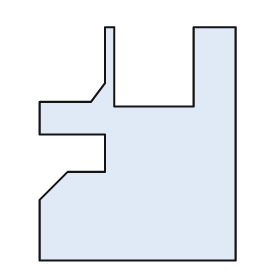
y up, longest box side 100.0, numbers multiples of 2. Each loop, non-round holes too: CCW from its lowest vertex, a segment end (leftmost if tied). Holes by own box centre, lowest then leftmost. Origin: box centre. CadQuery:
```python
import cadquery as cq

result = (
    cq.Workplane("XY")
    .moveTo(-42.0, -50.0)
    .lineTo(42.0, -50.0)
    .lineTo(42.0, 50.0)
    .lineTo(24.0, 50.0)
    .lineTo(24.0, 16.0)
    .lineTo(-10.0, 16.0)
    .lineTo(-10.0, 50.0)
    .lineTo(-14.0, 50.0)
    .lineTo(-14.0, 26.0)
    .lineTo(-20.0, 18.0)
    .lineTo(-42.0, 18.0)
    .lineTo(-42.0, 4.0)
    .lineTo(-14.0, 4.0)
    .lineTo(-14.0, -12.0)
    .lineTo(-30.0, -12.0)
    .lineTo(-42.0, -24.0)
    .close()
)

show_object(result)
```